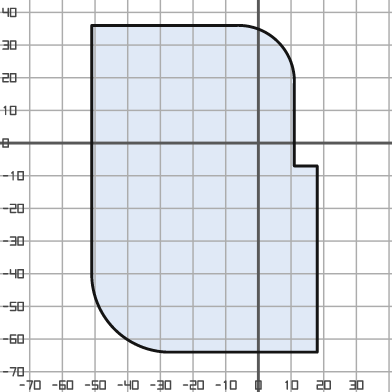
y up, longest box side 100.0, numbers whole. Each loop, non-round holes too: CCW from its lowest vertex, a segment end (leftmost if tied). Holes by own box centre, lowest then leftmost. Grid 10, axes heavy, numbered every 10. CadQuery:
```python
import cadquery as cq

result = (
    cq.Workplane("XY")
    .moveTo(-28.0, -64.0)
    .lineTo(18.0, -64.0)
    .lineTo(18.0, -7.0)
    .lineTo(11.0, -7.0)
    .lineTo(11.0, 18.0)
    .threePointArc((6.0, 31.0), (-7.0, 36.0))
    .lineTo(-51.0, 36.0)
    .lineTo(-51.0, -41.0)
    .threePointArc((-44.0, -57.0), (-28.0, -64.0))
    .close()
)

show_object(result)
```